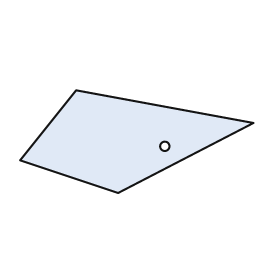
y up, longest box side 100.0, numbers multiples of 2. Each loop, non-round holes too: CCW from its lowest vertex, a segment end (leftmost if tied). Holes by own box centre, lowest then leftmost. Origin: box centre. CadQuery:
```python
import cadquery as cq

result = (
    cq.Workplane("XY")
    .moveTo(-8.0, -22.0)
    .lineTo(50.0, 8.0)
    .lineTo(-26.0, 22.0)
    .lineTo(-50.0, -8.0)
    .close()
    .moveTo(12.0, -2.0)
    .circle(2.0)
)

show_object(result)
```